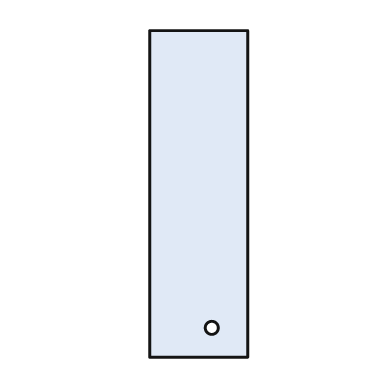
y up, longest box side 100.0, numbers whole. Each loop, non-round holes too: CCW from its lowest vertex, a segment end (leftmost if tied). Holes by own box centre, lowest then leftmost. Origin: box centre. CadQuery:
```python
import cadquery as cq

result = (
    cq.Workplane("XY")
    .moveTo(-15.0, -50.0)
    .lineTo(15.0, -50.0)
    .lineTo(15.0, 50.0)
    .lineTo(-15.0, 50.0)
    .close()
    .moveTo(4.0, -41.0)
    .circle(2.0)
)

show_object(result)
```